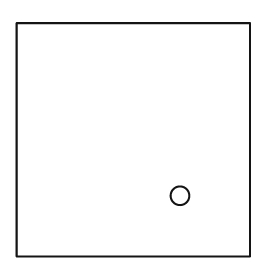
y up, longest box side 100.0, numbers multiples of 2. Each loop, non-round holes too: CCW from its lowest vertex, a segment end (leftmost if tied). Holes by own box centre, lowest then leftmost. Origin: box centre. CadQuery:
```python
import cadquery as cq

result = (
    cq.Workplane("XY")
    .moveTo(-50.0, -50.0)
    .lineTo(50.0, -50.0)
    .lineTo(50.0, 50.0)
    .lineTo(-50.0, 50.0)
    .close()
    .moveTo(20.0, -24.0)
    .circle(4.0)
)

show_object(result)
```